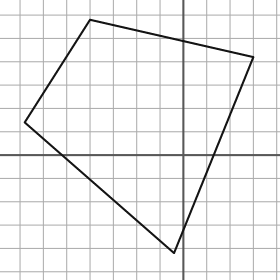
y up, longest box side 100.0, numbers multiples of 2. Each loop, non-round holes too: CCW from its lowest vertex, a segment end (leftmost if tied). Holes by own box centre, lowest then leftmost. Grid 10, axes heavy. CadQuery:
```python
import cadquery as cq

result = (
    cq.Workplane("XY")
    .moveTo(-4.0, -42.0)
    .lineTo(30.0, 42.0)
    .lineTo(-40.0, 58.0)
    .lineTo(-68.0, 14.0)
    .close()
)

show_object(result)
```